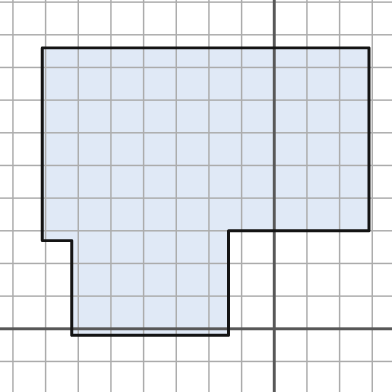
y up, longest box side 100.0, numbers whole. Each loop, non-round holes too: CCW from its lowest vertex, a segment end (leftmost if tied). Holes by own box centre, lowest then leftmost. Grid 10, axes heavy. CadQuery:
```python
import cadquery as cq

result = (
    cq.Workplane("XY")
    .moveTo(-62.0, -2.0)
    .lineTo(-14.0, -2.0)
    .lineTo(-14.0, 30.0)
    .lineTo(29.0, 30.0)
    .lineTo(29.0, 86.0)
    .lineTo(-71.0, 86.0)
    .lineTo(-71.0, 27.0)
    .lineTo(-62.0, 27.0)
    .close()
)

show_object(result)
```